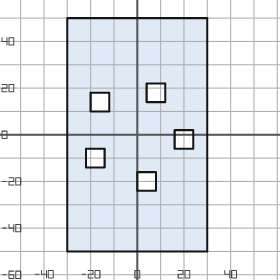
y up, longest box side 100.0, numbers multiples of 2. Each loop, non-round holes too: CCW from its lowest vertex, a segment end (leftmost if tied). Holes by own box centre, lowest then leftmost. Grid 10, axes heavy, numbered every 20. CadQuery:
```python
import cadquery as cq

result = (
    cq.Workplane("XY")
    .moveTo(-30.0, -50.0)
    .lineTo(30.0, -50.0)
    .lineTo(30.0, 50.0)
    .lineTo(-30.0, 50.0)
    .close()
    .moveTo(0.0, -24.0)
    .lineTo(8.0, -24.0)
    .lineTo(8.0, -16.0)
    .lineTo(0.0, -16.0)
    .close()
    .moveTo(-22.0, -14.0)
    .lineTo(-14.0, -14.0)
    .lineTo(-14.0, -6.0)
    .lineTo(-22.0, -6.0)
    .close()
    .moveTo(16.0, -6.0)
    .lineTo(24.0, -6.0)
    .lineTo(24.0, 2.0)
    .lineTo(16.0, 2.0)
    .close()
    .moveTo(-20.0, 10.0)
    .lineTo(-12.0, 10.0)
    .lineTo(-12.0, 18.0)
    .lineTo(-20.0, 18.0)
    .close()
    .moveTo(4.0, 14.0)
    .lineTo(12.0, 14.0)
    .lineTo(12.0, 22.0)
    .lineTo(4.0, 22.0)
    .close()
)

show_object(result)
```